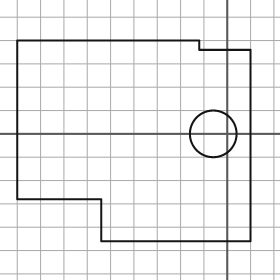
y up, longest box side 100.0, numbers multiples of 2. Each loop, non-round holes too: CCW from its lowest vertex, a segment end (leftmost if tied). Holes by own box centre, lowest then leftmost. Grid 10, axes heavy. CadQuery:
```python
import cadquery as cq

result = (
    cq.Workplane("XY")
    .moveTo(-54.0, -46.0)
    .lineTo(10.0, -46.0)
    .lineTo(10.0, 36.0)
    .lineTo(-12.0, 36.0)
    .lineTo(-12.0, 40.0)
    .lineTo(-90.0, 40.0)
    .lineTo(-90.0, -28.0)
    .lineTo(-54.0, -28.0)
    .close()
    .moveTo(-6.0, 0.0)
    .circle(10.0)
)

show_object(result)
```